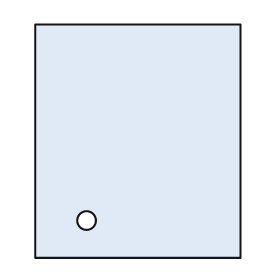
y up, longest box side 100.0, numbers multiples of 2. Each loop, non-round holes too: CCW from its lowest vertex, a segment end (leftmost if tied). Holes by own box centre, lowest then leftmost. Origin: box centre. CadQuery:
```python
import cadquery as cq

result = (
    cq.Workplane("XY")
    .moveTo(-44.0, -50.0)
    .lineTo(44.0, -50.0)
    .lineTo(44.0, 50.0)
    .lineTo(-44.0, 50.0)
    .close()
    .moveTo(-22.0, -34.0)
    .circle(4.0)
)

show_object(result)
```